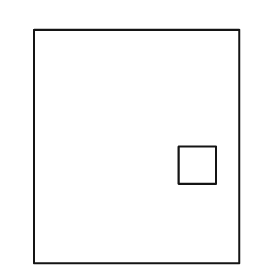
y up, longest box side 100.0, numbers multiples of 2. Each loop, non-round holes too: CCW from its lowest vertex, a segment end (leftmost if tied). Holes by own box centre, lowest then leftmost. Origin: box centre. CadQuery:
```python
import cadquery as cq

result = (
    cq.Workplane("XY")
    .moveTo(-44.0, -50.0)
    .lineTo(44.0, -50.0)
    .lineTo(44.0, 50.0)
    .lineTo(-44.0, 50.0)
    .close()
    .moveTo(18.0, -16.0)
    .lineTo(34.0, -16.0)
    .lineTo(34.0, 0.0)
    .lineTo(18.0, 0.0)
    .close()
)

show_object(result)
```